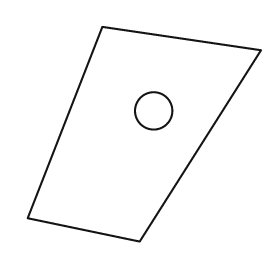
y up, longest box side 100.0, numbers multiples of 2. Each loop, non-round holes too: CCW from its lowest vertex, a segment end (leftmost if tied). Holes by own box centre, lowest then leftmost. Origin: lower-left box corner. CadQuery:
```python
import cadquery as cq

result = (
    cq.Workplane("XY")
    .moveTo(48.0, 0.0)
    .lineTo(100.0, 82.0)
    .lineTo(32.0, 92.0)
    .lineTo(0.0, 10.0)
    .close()
    .moveTo(54.0, 56.0)
    .circle(8.0)
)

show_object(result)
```